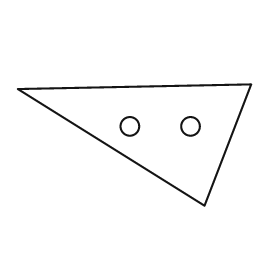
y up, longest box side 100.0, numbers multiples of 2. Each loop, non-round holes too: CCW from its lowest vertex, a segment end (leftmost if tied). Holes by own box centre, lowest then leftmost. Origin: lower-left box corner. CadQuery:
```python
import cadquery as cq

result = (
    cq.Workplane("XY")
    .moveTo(80.0, 0.0)
    .lineTo(100.0, 52.0)
    .lineTo(0.0, 50.0)
    .close()
    .moveTo(48.0, 34.0)
    .circle(4.0)
    .moveTo(74.0, 34.0)
    .circle(4.0)
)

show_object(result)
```